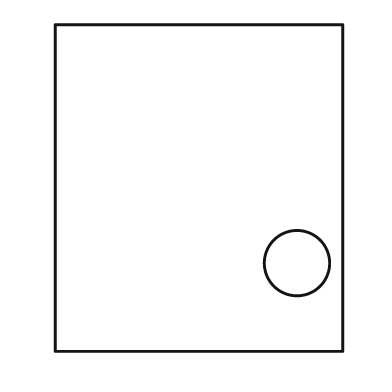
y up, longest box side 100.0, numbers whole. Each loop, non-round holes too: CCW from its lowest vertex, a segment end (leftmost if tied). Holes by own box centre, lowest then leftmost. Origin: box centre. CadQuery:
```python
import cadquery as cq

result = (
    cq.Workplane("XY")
    .moveTo(-44.0, -50.0)
    .lineTo(44.0, -50.0)
    .lineTo(44.0, 50.0)
    .lineTo(-44.0, 50.0)
    .close()
    .moveTo(30.0, -23.0)
    .circle(10.0)
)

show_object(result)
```